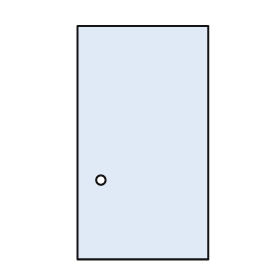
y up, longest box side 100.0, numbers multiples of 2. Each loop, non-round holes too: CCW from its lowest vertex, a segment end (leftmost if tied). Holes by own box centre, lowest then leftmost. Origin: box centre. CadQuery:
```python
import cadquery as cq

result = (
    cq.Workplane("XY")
    .moveTo(-28.0, -50.0)
    .lineTo(28.0, -50.0)
    .lineTo(28.0, 50.0)
    .lineTo(-28.0, 50.0)
    .close()
    .moveTo(-18.0, -16.0)
    .circle(2.0)
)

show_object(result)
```